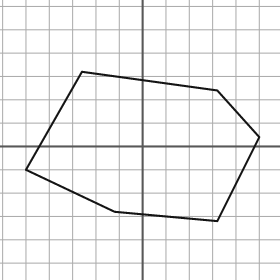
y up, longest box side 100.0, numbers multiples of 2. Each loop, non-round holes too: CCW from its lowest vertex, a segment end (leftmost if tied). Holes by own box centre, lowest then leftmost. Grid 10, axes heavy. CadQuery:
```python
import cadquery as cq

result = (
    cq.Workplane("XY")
    .moveTo(32.0, -32.0)
    .lineTo(50.0, 4.0)
    .lineTo(32.0, 24.0)
    .lineTo(-26.0, 32.0)
    .lineTo(-50.0, -10.0)
    .lineTo(-12.0, -28.0)
    .close()
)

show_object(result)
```